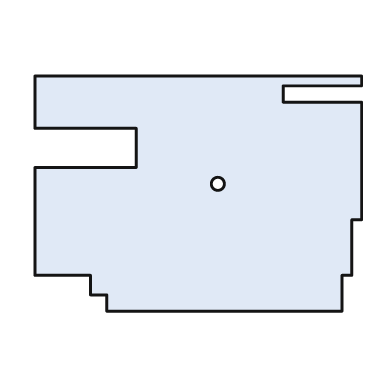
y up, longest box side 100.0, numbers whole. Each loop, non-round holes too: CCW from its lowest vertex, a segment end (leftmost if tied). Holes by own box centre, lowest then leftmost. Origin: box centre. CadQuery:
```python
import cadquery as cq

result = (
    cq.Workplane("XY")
    .moveTo(-28.0, -36.0)
    .lineTo(44.0, -36.0)
    .lineTo(44.0, -25.0)
    .lineTo(47.0, -25.0)
    .lineTo(47.0, -8.0)
    .lineTo(50.0, -8.0)
    .lineTo(50.0, 28.0)
    .lineTo(26.0, 28.0)
    .lineTo(26.0, 33.0)
    .lineTo(50.0, 33.0)
    .lineTo(50.0, 36.0)
    .lineTo(-50.0, 36.0)
    .lineTo(-50.0, 20.0)
    .lineTo(-19.0, 20.0)
    .lineTo(-19.0, 8.0)
    .lineTo(-50.0, 8.0)
    .lineTo(-50.0, -25.0)
    .lineTo(-33.0, -25.0)
    .lineTo(-33.0, -31.0)
    .lineTo(-28.0, -31.0)
    .close()
    .moveTo(6.0, 3.0)
    .circle(2.0)
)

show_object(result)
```